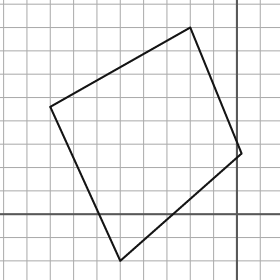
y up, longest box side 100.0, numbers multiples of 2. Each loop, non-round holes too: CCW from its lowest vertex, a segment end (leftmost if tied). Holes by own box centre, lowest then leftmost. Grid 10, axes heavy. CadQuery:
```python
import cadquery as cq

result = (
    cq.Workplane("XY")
    .moveTo(-50.0, -20.0)
    .lineTo(2.0, 26.0)
    .lineTo(-20.0, 80.0)
    .lineTo(-80.0, 46.0)
    .close()
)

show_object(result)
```